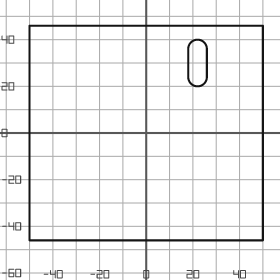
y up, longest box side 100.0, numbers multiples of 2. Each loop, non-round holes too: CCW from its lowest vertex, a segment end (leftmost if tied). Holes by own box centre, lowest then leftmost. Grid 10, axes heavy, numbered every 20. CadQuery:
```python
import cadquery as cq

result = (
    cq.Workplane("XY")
    .moveTo(-50.0, -46.0)
    .lineTo(50.0, -46.0)
    .lineTo(50.0, 46.0)
    .lineTo(-50.0, 46.0)
    .close()
    .moveTo(18.0, 24.0)
    .threePointArc((22.0, 20.0), (26.0, 24.0))
    .lineTo(26.0, 36.0)
    .threePointArc((22.0, 40.0), (18.0, 36.0))
    .close()
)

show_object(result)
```